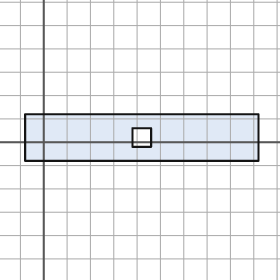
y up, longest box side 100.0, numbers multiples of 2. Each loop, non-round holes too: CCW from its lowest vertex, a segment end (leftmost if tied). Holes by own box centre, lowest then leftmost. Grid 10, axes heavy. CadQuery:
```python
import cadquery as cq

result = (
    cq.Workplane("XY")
    .moveTo(-8.0, -8.0)
    .lineTo(92.0, -8.0)
    .lineTo(92.0, 12.0)
    .lineTo(-8.0, 12.0)
    .close()
    .moveTo(38.0, -2.0)
    .lineTo(46.0, -2.0)
    .lineTo(46.0, 6.0)
    .lineTo(38.0, 6.0)
    .close()
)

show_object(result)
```